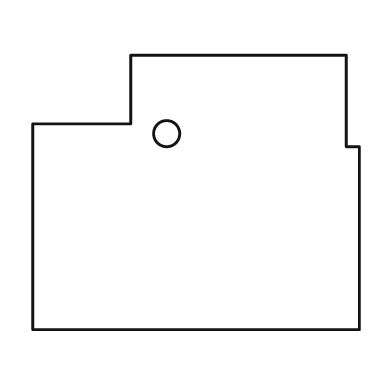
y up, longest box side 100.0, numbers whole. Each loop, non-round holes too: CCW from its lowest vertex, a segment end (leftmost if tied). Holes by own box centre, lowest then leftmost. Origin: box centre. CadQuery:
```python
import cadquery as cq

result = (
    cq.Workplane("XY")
    .moveTo(-50.0, -42.0)
    .lineTo(50.0, -42.0)
    .lineTo(50.0, 14.0)
    .lineTo(46.0, 14.0)
    .lineTo(46.0, 42.0)
    .lineTo(-20.0, 42.0)
    .lineTo(-20.0, 21.0)
    .lineTo(-50.0, 21.0)
    .close()
    .moveTo(-9.0, 18.0)
    .circle(4.0)
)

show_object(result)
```